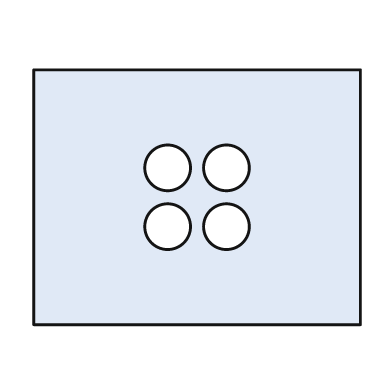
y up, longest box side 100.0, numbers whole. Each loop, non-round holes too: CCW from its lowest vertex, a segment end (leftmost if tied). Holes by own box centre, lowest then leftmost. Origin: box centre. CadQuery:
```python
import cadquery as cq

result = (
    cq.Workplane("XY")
    .moveTo(-50.0, -39.0)
    .lineTo(50.0, -39.0)
    .lineTo(50.0, 39.0)
    .lineTo(-50.0, 39.0)
    .close()
    .moveTo(-9.0, -9.0)
    .circle(7.0)
    .moveTo(9.0, -9.0)
    .circle(7.0)
    .moveTo(-9.0, 9.0)
    .circle(7.0)
    .moveTo(9.0, 9.0)
    .circle(7.0)
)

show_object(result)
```